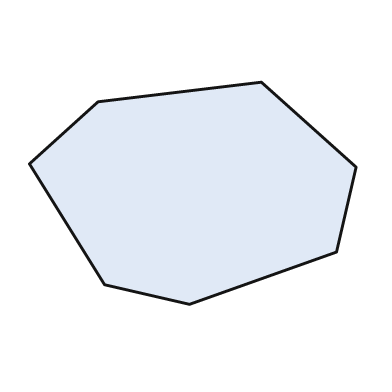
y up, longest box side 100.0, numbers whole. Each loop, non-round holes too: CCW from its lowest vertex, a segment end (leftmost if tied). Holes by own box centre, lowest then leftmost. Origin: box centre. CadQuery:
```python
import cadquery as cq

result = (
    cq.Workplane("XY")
    .moveTo(-1.0, -34.0)
    .lineTo(44.0, -18.0)
    .lineTo(50.0, 8.0)
    .lineTo(21.0, 34.0)
    .lineTo(-29.0, 28.0)
    .lineTo(-50.0, 9.0)
    .lineTo(-27.0, -28.0)
    .close()
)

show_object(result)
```